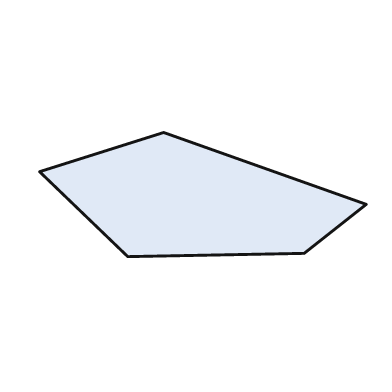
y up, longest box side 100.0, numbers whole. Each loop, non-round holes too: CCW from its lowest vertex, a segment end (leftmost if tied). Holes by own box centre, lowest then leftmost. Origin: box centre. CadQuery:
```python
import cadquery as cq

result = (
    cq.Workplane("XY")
    .moveTo(-23.0, -19.0)
    .lineTo(31.0, -18.0)
    .lineTo(50.0, -3.0)
    .lineTo(-12.0, 19.0)
    .lineTo(-50.0, 7.0)
    .close()
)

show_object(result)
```